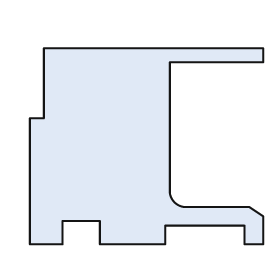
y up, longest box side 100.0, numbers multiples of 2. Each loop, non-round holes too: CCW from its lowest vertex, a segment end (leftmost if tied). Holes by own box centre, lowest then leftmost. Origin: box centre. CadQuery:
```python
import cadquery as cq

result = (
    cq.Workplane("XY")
    .moveTo(-50.0, -42.0)
    .lineTo(-36.0, -42.0)
    .lineTo(-36.0, -32.0)
    .lineTo(-20.0, -32.0)
    .lineTo(-20.0, -42.0)
    .lineTo(8.0, -42.0)
    .lineTo(8.0, -34.0)
    .lineTo(42.0, -34.0)
    .lineTo(42.0, -42.0)
    .lineTo(50.0, -42.0)
    .lineTo(50.0, -30.0)
    .lineTo(44.0, -26.0)
    .lineTo(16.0, -26.0)
    .threePointArc((12.0, -24.0), (10.0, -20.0))
    .lineTo(10.0, 36.0)
    .lineTo(50.0, 36.0)
    .lineTo(50.0, 42.0)
    .lineTo(-44.0, 42.0)
    .lineTo(-44.0, 12.0)
    .lineTo(-50.0, 12.0)
    .close()
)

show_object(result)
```